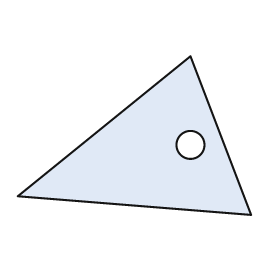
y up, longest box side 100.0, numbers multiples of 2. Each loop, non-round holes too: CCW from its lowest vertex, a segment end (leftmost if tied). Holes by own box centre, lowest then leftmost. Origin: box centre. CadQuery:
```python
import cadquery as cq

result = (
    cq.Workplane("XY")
    .moveTo(50.0, -34.0)
    .lineTo(24.0, 34.0)
    .lineTo(-50.0, -26.0)
    .close()
    .moveTo(24.0, -4.0)
    .circle(6.0)
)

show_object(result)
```